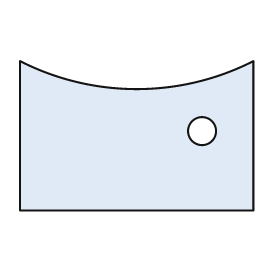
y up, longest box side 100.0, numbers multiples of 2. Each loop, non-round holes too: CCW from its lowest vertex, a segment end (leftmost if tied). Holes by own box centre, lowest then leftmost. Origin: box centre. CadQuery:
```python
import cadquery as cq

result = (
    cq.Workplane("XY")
    .moveTo(-50.0, -32.0)
    .lineTo(50.0, -32.0)
    .lineTo(50.0, 32.0)
    .threePointArc((0.0, 20.0), (-50.0, 32.0))
    .close()
    .moveTo(28.0, 2.0)
    .circle(6.0)
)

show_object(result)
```